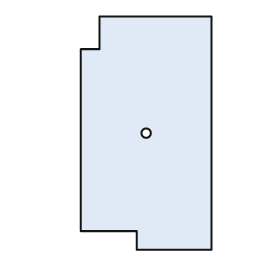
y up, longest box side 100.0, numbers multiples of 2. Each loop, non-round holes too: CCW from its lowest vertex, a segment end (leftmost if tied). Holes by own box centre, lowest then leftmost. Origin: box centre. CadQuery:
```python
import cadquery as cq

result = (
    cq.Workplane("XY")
    .moveTo(-4.0, -50.0)
    .lineTo(28.0, -50.0)
    .lineTo(28.0, 50.0)
    .lineTo(-20.0, 50.0)
    .lineTo(-20.0, 36.0)
    .lineTo(-28.0, 36.0)
    .lineTo(-28.0, -42.0)
    .lineTo(-4.0, -42.0)
    .close()
    .moveTo(0.0, 0.0)
    .circle(2.0)
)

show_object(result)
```